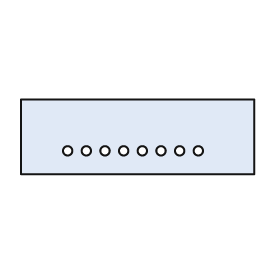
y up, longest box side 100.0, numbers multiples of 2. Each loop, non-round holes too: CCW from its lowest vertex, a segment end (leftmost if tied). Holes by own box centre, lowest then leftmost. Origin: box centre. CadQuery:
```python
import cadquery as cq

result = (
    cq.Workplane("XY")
    .moveTo(-50.0, -16.0)
    .lineTo(50.0, -16.0)
    .lineTo(50.0, 16.0)
    .lineTo(-50.0, 16.0)
    .close()
    .moveTo(-30.0, -6.0)
    .circle(2.0)
    .moveTo(-22.0, -6.0)
    .circle(2.0)
    .moveTo(-14.0, -6.0)
    .circle(2.0)
    .moveTo(-6.0, -6.0)
    .circle(2.0)
    .moveTo(2.0, -6.0)
    .circle(2.0)
    .moveTo(10.0, -6.0)
    .circle(2.0)
    .moveTo(18.0, -6.0)
    .circle(2.0)
    .moveTo(26.0, -6.0)
    .circle(2.0)
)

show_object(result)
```